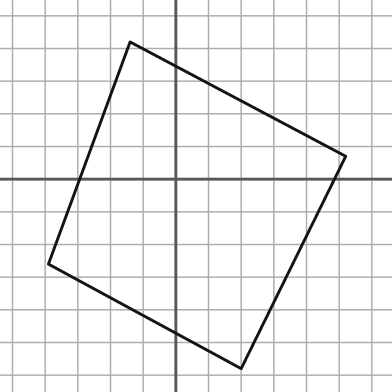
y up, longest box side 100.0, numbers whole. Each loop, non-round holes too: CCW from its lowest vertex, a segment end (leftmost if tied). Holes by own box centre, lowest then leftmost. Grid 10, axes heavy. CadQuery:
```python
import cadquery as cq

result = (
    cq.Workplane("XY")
    .moveTo(20.0, -58.0)
    .lineTo(52.0, 7.0)
    .lineTo(-14.0, 42.0)
    .lineTo(-39.0, -26.0)
    .close()
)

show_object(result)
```